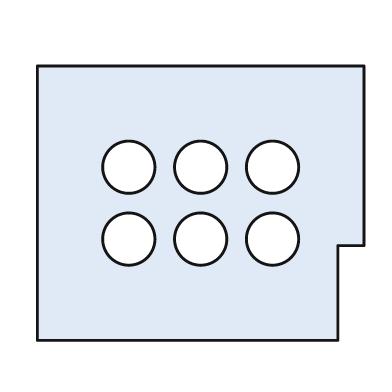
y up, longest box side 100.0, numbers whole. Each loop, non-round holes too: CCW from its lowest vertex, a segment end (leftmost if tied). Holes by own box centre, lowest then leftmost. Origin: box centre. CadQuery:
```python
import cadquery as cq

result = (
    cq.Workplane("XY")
    .moveTo(-50.0, -42.0)
    .lineTo(42.0, -42.0)
    .lineTo(42.0, -13.0)
    .lineTo(50.0, -13.0)
    .lineTo(50.0, 42.0)
    .lineTo(-50.0, 42.0)
    .close()
    .moveTo(-22.0, -11.0)
    .circle(8.0)
    .moveTo(0.0, -11.0)
    .circle(8.0)
    .moveTo(22.0, -11.0)
    .circle(8.0)
    .moveTo(-22.0, 11.0)
    .circle(8.0)
    .moveTo(0.0, 11.0)
    .circle(8.0)
    .moveTo(22.0, 11.0)
    .circle(8.0)
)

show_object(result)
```